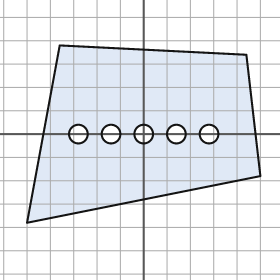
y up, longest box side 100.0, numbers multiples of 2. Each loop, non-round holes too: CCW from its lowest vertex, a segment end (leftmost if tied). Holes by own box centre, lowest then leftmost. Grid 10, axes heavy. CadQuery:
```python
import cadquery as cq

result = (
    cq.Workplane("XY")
    .moveTo(-50.0, -38.0)
    .lineTo(50.0, -18.0)
    .lineTo(44.0, 34.0)
    .lineTo(-36.0, 38.0)
    .close()
    .moveTo(-28.0, 0.0)
    .circle(4.0)
    .moveTo(-14.0, 0.0)
    .circle(4.0)
    .moveTo(0.0, 0.0)
    .circle(4.0)
    .moveTo(14.0, 0.0)
    .circle(4.0)
    .moveTo(28.0, 0.0)
    .circle(4.0)
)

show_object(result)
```